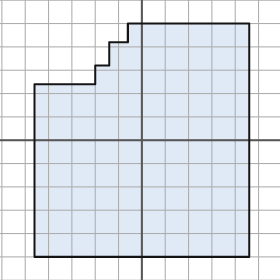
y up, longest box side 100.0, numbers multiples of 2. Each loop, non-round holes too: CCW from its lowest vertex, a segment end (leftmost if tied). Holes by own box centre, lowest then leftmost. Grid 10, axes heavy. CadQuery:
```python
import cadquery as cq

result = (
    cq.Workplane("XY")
    .moveTo(-46.0, -50.0)
    .lineTo(46.0, -50.0)
    .lineTo(46.0, 50.0)
    .lineTo(-6.0, 50.0)
    .lineTo(-6.0, 42.0)
    .lineTo(-14.0, 42.0)
    .lineTo(-14.0, 32.0)
    .lineTo(-20.0, 32.0)
    .lineTo(-20.0, 24.0)
    .lineTo(-46.0, 24.0)
    .close()
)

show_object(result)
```